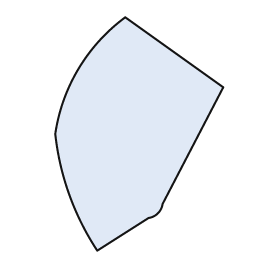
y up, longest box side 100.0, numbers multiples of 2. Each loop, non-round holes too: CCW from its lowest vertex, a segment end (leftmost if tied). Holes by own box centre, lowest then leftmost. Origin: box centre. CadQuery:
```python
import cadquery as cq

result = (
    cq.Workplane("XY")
    .moveTo(-18.0, -50.0)
    .lineTo(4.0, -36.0)
    .threePointArc((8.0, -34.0), (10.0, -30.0))
    .lineTo(36.0, 20.0)
    .lineTo(-6.0, 50.0)
    .threePointArc((-26.0, 28.0), (-36.0, 0.0))
    .threePointArc((-30.0, -26.0), (-18.0, -50.0))
    .close()
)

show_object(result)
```